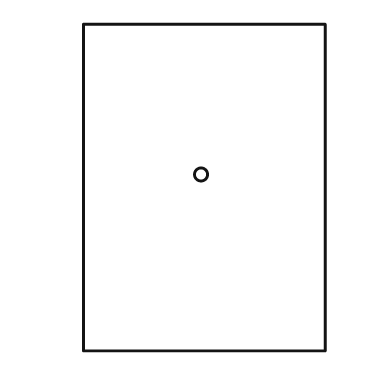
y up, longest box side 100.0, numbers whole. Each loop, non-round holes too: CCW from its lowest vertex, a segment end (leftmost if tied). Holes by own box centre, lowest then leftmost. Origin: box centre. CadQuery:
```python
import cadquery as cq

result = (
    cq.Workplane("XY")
    .moveTo(-37.0, -50.0)
    .lineTo(37.0, -50.0)
    .lineTo(37.0, 50.0)
    .lineTo(-37.0, 50.0)
    .close()
    .moveTo(-1.0, 4.0)
    .circle(2.0)
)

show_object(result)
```